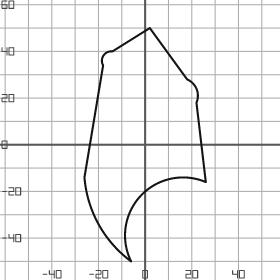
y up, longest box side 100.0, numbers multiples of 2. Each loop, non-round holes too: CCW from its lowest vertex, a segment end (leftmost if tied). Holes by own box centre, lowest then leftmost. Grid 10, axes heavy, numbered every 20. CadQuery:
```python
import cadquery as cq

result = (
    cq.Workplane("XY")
    .moveTo(-6.0, -50.0)
    .threePointArc((-2.0, -22.0), (26.0, -16.0))
    .lineTo(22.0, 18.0)
    .threePointArc((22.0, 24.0), (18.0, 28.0))
    .lineTo(2.0, 50.0)
    .lineTo(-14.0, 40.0)
    .threePointArc((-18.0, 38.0), (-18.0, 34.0))
    .lineTo(-26.0, -14.0)
    .threePointArc((-20.0, -34.0), (-6.0, -50.0))
    .close()
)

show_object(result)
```